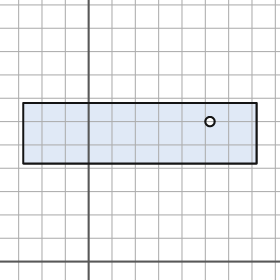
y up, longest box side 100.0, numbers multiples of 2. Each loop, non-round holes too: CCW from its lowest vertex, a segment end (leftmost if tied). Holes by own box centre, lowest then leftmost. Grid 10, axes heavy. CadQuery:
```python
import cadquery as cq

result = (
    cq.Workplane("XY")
    .moveTo(-28.0, 42.0)
    .lineTo(72.0, 42.0)
    .lineTo(72.0, 68.0)
    .lineTo(-28.0, 68.0)
    .close()
    .moveTo(52.0, 60.0)
    .circle(2.0)
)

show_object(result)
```